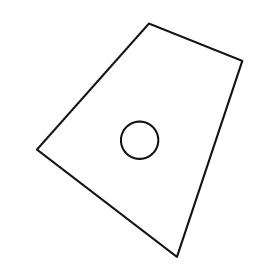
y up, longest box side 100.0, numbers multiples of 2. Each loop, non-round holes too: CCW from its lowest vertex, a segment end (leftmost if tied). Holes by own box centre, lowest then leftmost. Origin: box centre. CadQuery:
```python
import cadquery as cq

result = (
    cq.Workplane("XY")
    .moveTo(16.0, -50.0)
    .lineTo(44.0, 34.0)
    .lineTo(4.0, 50.0)
    .lineTo(-44.0, -4.0)
    .close()
    .moveTo(0.0, 0.0)
    .circle(8.0)
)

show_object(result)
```